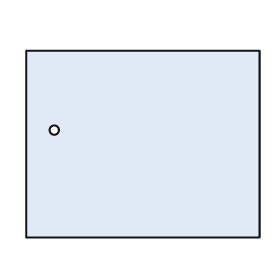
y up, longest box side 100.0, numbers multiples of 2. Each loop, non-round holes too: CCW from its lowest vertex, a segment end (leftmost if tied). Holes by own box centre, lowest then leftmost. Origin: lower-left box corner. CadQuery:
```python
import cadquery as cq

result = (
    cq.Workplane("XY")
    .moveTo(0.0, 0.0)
    .lineTo(100.0, 0.0)
    .lineTo(100.0, 80.0)
    .lineTo(0.0, 80.0)
    .close()
    .moveTo(12.0, 46.0)
    .circle(2.0)
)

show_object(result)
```